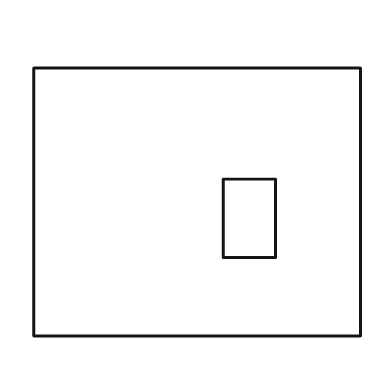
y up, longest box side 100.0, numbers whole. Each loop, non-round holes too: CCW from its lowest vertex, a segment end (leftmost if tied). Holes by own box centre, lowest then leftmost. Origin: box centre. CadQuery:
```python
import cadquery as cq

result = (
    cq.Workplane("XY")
    .moveTo(-50.0, -41.0)
    .lineTo(50.0, -41.0)
    .lineTo(50.0, 41.0)
    .lineTo(-50.0, 41.0)
    .close()
    .moveTo(8.0, -17.0)
    .lineTo(24.0, -17.0)
    .lineTo(24.0, 7.0)
    .lineTo(8.0, 7.0)
    .close()
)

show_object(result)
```